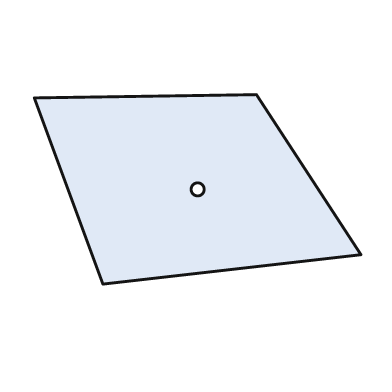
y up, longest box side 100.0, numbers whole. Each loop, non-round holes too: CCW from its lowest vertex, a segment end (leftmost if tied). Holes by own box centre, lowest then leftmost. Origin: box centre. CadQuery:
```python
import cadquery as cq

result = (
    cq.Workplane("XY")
    .moveTo(-29.0, -29.0)
    .lineTo(50.0, -20.0)
    .lineTo(18.0, 29.0)
    .lineTo(-50.0, 28.0)
    .close()
    .moveTo(0.0, 0.0)
    .circle(2.0)
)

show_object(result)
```